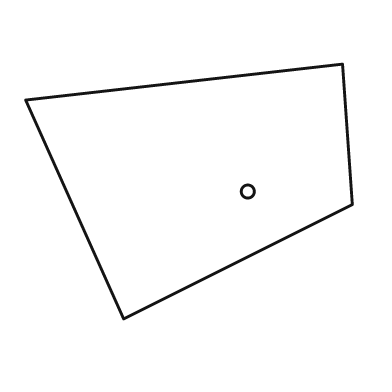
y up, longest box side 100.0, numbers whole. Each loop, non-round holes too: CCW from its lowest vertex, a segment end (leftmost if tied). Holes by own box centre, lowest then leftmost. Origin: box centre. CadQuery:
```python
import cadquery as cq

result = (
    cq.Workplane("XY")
    .moveTo(-20.0, -39.0)
    .lineTo(50.0, -4.0)
    .lineTo(47.0, 39.0)
    .lineTo(-50.0, 28.0)
    .close()
    .moveTo(18.0, 0.0)
    .circle(2.0)
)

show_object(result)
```